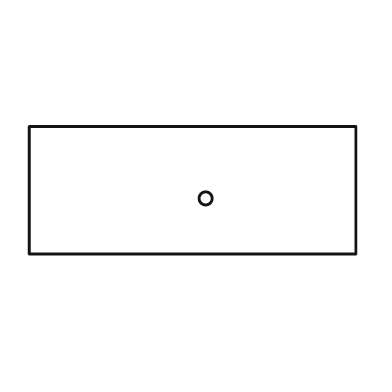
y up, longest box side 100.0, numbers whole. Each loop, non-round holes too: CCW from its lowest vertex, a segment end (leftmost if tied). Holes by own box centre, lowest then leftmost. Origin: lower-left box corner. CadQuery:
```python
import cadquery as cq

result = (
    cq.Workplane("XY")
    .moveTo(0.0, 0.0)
    .lineTo(100.0, 0.0)
    .lineTo(100.0, 39.0)
    .lineTo(0.0, 39.0)
    .close()
    .moveTo(54.0, 17.0)
    .circle(2.0)
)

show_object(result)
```